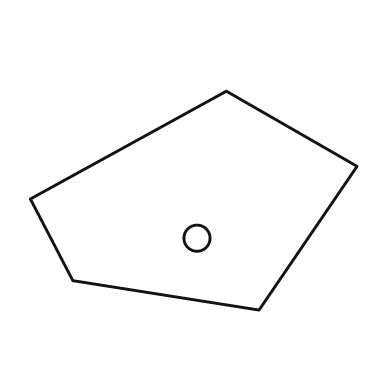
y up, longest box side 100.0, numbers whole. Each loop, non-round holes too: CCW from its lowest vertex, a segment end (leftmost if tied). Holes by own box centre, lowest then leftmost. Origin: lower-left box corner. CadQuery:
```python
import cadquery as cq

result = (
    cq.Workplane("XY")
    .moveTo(70.0, 0.0)
    .lineTo(100.0, 44.0)
    .lineTo(60.0, 67.0)
    .lineTo(0.0, 34.0)
    .lineTo(13.0, 9.0)
    .close()
    .moveTo(51.0, 22.0)
    .circle(4.0)
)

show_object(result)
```